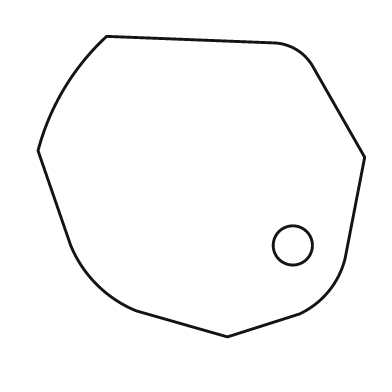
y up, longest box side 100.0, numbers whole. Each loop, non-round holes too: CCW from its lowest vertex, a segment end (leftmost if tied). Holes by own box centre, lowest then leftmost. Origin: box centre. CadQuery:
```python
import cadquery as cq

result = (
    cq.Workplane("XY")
    .moveTo(8.0, -46.0)
    .lineTo(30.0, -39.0)
    .threePointArc((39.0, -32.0), (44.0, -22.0))
    .lineTo(50.0, 9.0)
    .lineTo(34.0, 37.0)
    .threePointArc((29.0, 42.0), (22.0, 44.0))
    .lineTo(-29.0, 46.0)
    .threePointArc((-42.0, 30.0), (-50.0, 11.0))
    .lineTo(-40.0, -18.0)
    .threePointArc((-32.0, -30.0), (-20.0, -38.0))
    .close()
    .moveTo(28.0, -18.0)
    .circle(6.0)
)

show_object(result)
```